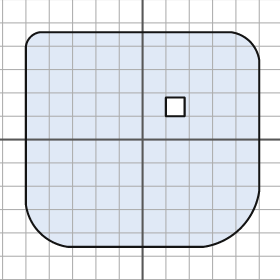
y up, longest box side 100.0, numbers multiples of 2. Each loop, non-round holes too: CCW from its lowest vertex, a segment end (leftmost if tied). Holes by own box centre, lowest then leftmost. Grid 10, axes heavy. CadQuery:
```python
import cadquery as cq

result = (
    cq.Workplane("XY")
    .moveTo(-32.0, -46.0)
    .lineTo(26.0, -46.0)
    .threePointArc((42.0, -38.0), (50.0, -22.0))
    .lineTo(50.0, 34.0)
    .threePointArc((46.0, 42.0), (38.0, 46.0))
    .lineTo(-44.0, 46.0)
    .threePointArc((-48.0, 44.0), (-50.0, 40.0))
    .lineTo(-50.0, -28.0)
    .threePointArc((-44.0, -40.0), (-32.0, -46.0))
    .close()
    .moveTo(10.0, 10.0)
    .lineTo(18.0, 10.0)
    .lineTo(18.0, 18.0)
    .lineTo(10.0, 18.0)
    .close()
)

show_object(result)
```